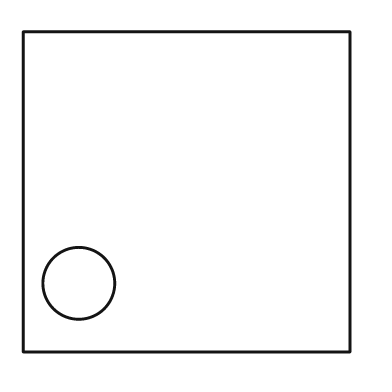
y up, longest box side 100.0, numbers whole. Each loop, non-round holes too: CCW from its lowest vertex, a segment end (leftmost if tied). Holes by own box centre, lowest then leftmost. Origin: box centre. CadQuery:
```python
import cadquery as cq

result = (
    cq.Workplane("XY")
    .moveTo(-50.0, -49.0)
    .lineTo(50.0, -49.0)
    .lineTo(50.0, 49.0)
    .lineTo(-50.0, 49.0)
    .close()
    .moveTo(-33.0, -28.0)
    .circle(11.0)
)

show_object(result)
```